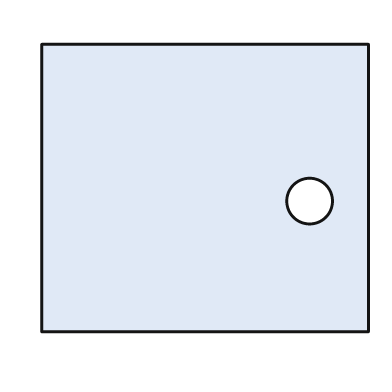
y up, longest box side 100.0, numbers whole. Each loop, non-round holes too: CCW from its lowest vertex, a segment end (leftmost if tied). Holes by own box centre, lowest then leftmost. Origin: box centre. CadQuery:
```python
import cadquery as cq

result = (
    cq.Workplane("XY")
    .moveTo(-50.0, -44.0)
    .lineTo(50.0, -44.0)
    .lineTo(50.0, 44.0)
    .lineTo(-50.0, 44.0)
    .close()
    .moveTo(32.0, -4.0)
    .circle(7.0)
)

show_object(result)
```